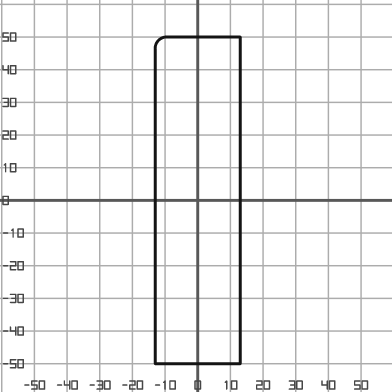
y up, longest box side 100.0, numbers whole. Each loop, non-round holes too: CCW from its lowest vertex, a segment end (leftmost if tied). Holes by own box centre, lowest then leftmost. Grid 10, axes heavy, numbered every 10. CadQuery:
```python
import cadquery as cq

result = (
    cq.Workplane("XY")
    .moveTo(-13.0, -50.0)
    .lineTo(13.0, -50.0)
    .lineTo(13.0, 50.0)
    .lineTo(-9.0, 50.0)
    .threePointArc((-12.0, 49.0), (-13.0, 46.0))
    .close()
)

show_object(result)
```